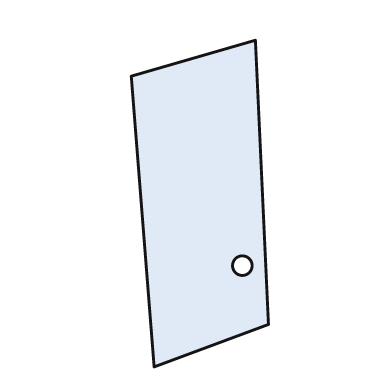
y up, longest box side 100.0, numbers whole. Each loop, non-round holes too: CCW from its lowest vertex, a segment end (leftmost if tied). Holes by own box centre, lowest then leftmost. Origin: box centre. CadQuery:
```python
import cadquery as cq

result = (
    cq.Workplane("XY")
    .moveTo(-14.0, -50.0)
    .lineTo(21.0, -37.0)
    .lineTo(17.0, 50.0)
    .lineTo(-21.0, 39.0)
    .close()
    .moveTo(13.0, -19.0)
    .circle(3.0)
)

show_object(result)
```